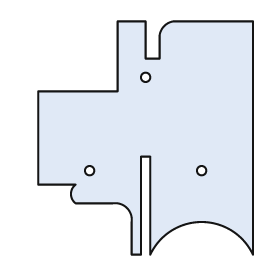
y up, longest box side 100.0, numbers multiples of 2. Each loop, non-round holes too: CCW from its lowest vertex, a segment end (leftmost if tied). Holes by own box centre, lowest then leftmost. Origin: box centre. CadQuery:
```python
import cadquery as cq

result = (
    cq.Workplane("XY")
    .moveTo(-6.0, -50.0)
    .lineTo(-2.0, -50.0)
    .lineTo(-2.0, -8.0)
    .lineTo(2.0, -8.0)
    .lineTo(2.0, -50.0)
    .threePointArc((24.0, -36.0), (46.0, -50.0))
    .lineTo(46.0, 50.0)
    .lineTo(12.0, 50.0)
    .threePointArc((8.0, 48.0), (6.0, 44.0))
    .lineTo(6.0, 34.0)
    .lineTo(0.0, 34.0)
    .lineTo(0.0, 50.0)
    .lineTo(-12.0, 50.0)
    .lineTo(-12.0, 20.0)
    .lineTo(-46.0, 20.0)
    .lineTo(-46.0, -20.0)
    .lineTo(-30.0, -20.0)
    .threePointArc((-32.0, -24.0), (-30.0, -28.0))
    .lineTo(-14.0, -28.0)
    .threePointArc((-8.0, -30.0), (-6.0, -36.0))
    .close()
    .moveTo(-24.0, -14.0)
    .circle(2.0)
    .moveTo(24.0, -14.0)
    .circle(2.0)
    .moveTo(0.0, 26.0)
    .circle(2.0)
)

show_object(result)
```